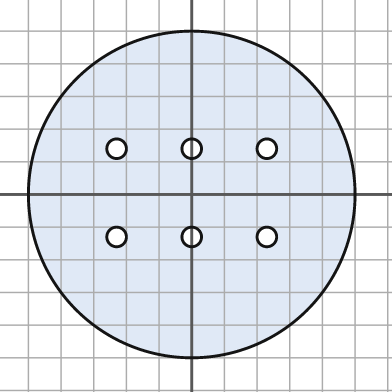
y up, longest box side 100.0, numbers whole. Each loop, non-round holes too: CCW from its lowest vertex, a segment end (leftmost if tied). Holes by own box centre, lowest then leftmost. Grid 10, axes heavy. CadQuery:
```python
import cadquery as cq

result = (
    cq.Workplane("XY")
    .moveTo(0.0, 0.0)
    .circle(50.0)
    .moveTo(-23.0, -13.0)
    .circle(3.0)
    .moveTo(0.0, -13.0)
    .circle(3.0)
    .moveTo(23.0, -13.0)
    .circle(3.0)
    .moveTo(-23.0, 14.0)
    .circle(3.0)
    .moveTo(0.0, 14.0)
    .circle(3.0)
    .moveTo(23.0, 14.0)
    .circle(3.0)
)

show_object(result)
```